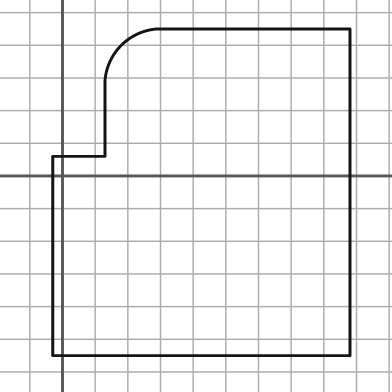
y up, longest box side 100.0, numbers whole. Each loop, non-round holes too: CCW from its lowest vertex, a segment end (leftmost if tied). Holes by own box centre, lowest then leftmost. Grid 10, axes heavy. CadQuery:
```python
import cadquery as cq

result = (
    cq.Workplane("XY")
    .moveTo(-3.0, -55.0)
    .lineTo(88.0, -55.0)
    .lineTo(88.0, 45.0)
    .lineTo(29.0, 45.0)
    .threePointArc((18.0, 40.0), (13.0, 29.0))
    .lineTo(13.0, 6.0)
    .lineTo(-3.0, 6.0)
    .close()
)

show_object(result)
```